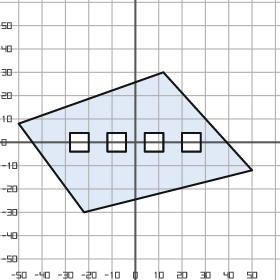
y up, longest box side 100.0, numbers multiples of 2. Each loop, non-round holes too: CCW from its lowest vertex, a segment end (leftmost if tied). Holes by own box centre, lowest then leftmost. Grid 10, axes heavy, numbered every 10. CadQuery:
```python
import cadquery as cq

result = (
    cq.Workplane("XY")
    .moveTo(-22.0, -30.0)
    .lineTo(50.0, -12.0)
    .lineTo(12.0, 30.0)
    .lineTo(-50.0, 8.0)
    .close()
    .moveTo(-28.0, -4.0)
    .lineTo(-20.0, -4.0)
    .lineTo(-20.0, 4.0)
    .lineTo(-28.0, 4.0)
    .close()
    .moveTo(-12.0, -4.0)
    .lineTo(-4.0, -4.0)
    .lineTo(-4.0, 4.0)
    .lineTo(-12.0, 4.0)
    .close()
    .moveTo(4.0, -4.0)
    .lineTo(12.0, -4.0)
    .lineTo(12.0, 4.0)
    .lineTo(4.0, 4.0)
    .close()
    .moveTo(20.0, -4.0)
    .lineTo(28.0, -4.0)
    .lineTo(28.0, 4.0)
    .lineTo(20.0, 4.0)
    .close()
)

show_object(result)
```